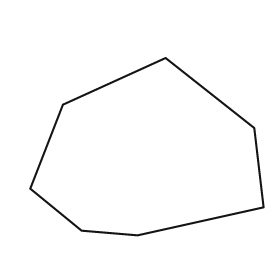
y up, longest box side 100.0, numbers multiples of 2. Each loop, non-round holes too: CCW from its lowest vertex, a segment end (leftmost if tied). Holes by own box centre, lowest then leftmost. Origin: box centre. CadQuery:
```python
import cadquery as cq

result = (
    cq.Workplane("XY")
    .moveTo(-4.0, -38.0)
    .lineTo(50.0, -26.0)
    .lineTo(46.0, 8.0)
    .lineTo(8.0, 38.0)
    .lineTo(-36.0, 18.0)
    .lineTo(-50.0, -18.0)
    .lineTo(-28.0, -36.0)
    .close()
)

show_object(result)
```